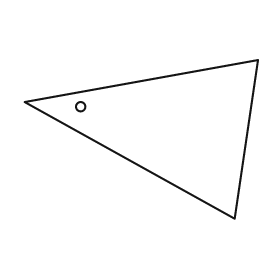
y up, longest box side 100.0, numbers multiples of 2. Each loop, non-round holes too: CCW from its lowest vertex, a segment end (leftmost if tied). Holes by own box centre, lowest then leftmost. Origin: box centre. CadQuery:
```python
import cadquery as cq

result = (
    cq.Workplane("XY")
    .moveTo(40.0, -34.0)
    .lineTo(50.0, 34.0)
    .lineTo(-50.0, 16.0)
    .close()
    .moveTo(-26.0, 14.0)
    .circle(2.0)
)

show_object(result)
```